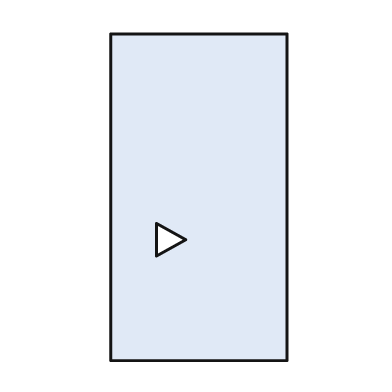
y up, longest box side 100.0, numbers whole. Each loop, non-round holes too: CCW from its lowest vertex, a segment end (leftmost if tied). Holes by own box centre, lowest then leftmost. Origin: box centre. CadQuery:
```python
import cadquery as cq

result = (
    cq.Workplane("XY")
    .moveTo(-27.0, -50.0)
    .lineTo(27.0, -50.0)
    .lineTo(27.0, 50.0)
    .lineTo(-27.0, 50.0)
    .close()
    .moveTo(-13.0, -18.0)
    .lineTo(-4.0, -13.0)
    .lineTo(-13.0, -8.0)
    .close()
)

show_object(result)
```